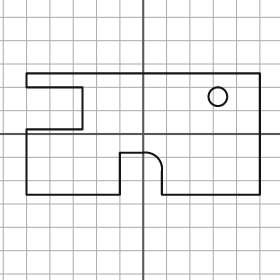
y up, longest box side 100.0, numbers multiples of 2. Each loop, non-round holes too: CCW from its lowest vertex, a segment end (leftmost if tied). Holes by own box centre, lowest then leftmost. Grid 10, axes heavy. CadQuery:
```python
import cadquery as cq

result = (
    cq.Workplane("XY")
    .moveTo(-50.0, -26.0)
    .lineTo(-10.0, -26.0)
    .lineTo(-10.0, -8.0)
    .lineTo(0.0, -8.0)
    .threePointArc((6.0, -10.0), (8.0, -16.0))
    .lineTo(8.0, -26.0)
    .lineTo(50.0, -26.0)
    .lineTo(50.0, 26.0)
    .lineTo(-50.0, 26.0)
    .lineTo(-50.0, 20.0)
    .lineTo(-26.0, 20.0)
    .lineTo(-26.0, 2.0)
    .lineTo(-50.0, 2.0)
    .close()
    .moveTo(32.0, 16.0)
    .circle(4.0)
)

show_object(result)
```